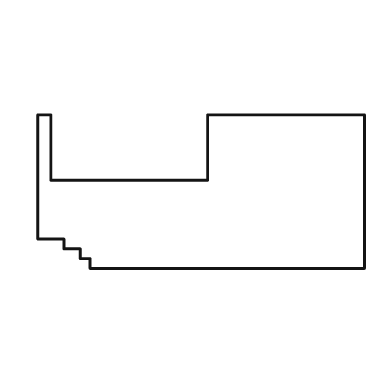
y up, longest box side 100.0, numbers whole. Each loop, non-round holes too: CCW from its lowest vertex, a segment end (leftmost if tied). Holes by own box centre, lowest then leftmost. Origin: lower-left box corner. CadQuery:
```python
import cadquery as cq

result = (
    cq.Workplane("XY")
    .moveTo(16.0, 0.0)
    .lineTo(100.0, 0.0)
    .lineTo(100.0, 47.0)
    .lineTo(52.0, 47.0)
    .lineTo(52.0, 27.0)
    .lineTo(4.0, 27.0)
    .lineTo(4.0, 47.0)
    .lineTo(0.0, 47.0)
    .lineTo(0.0, 9.0)
    .lineTo(8.0, 9.0)
    .lineTo(8.0, 6.0)
    .lineTo(13.0, 6.0)
    .lineTo(13.0, 3.0)
    .lineTo(16.0, 3.0)
    .close()
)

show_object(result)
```